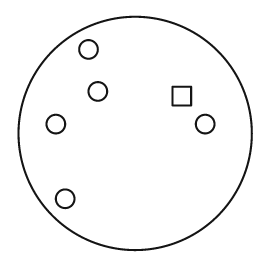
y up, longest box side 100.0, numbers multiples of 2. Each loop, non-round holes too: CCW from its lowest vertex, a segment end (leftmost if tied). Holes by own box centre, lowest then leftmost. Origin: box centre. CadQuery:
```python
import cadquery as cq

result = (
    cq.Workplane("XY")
    .moveTo(0.0, 0.0)
    .circle(50.0)
    .moveTo(-30.0, -28.0)
    .circle(4.0)
    .moveTo(-34.0, 4.0)
    .circle(4.0)
    .moveTo(30.0, 4.0)
    .circle(4.0)
    .moveTo(16.0, 12.0)
    .lineTo(24.0, 12.0)
    .lineTo(24.0, 20.0)
    .lineTo(16.0, 20.0)
    .close()
    .moveTo(-16.0, 18.0)
    .circle(4.0)
    .moveTo(-20.0, 36.0)
    .circle(4.0)
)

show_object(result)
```